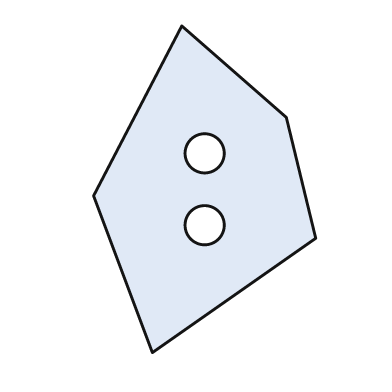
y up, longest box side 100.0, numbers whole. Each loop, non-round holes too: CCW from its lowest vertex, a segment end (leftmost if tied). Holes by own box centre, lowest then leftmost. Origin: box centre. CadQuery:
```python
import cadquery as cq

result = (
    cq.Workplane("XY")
    .moveTo(-16.0, -50.0)
    .lineTo(34.0, -15.0)
    .lineTo(25.0, 22.0)
    .lineTo(-7.0, 50.0)
    .lineTo(-34.0, -2.0)
    .close()
    .moveTo(0.0, -11.0)
    .circle(6.0)
    .moveTo(0.0, 11.0)
    .circle(6.0)
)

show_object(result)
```